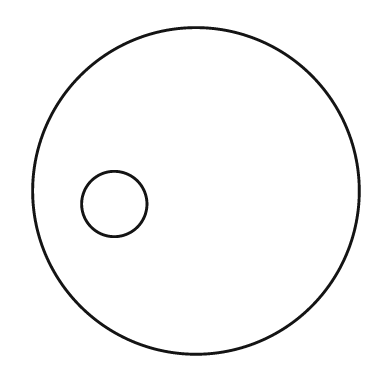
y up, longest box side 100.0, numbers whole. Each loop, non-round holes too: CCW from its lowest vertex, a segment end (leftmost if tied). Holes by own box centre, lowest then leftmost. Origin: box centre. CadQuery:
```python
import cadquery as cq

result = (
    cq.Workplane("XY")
    .moveTo(0.0, 0.0)
    .circle(50.0)
    .moveTo(-25.0, -4.0)
    .circle(10.0)
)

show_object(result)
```